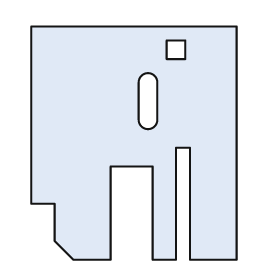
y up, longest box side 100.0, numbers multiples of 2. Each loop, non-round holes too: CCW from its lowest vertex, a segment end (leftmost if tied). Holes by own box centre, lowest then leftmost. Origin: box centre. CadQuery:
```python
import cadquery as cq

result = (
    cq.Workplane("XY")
    .moveTo(-26.0, -50.0)
    .lineTo(-10.0, -50.0)
    .lineTo(-10.0, -10.0)
    .lineTo(8.0, -10.0)
    .lineTo(8.0, -50.0)
    .lineTo(18.0, -50.0)
    .lineTo(18.0, -2.0)
    .lineTo(24.0, -2.0)
    .lineTo(24.0, -50.0)
    .lineTo(44.0, -50.0)
    .lineTo(44.0, 50.0)
    .lineTo(-44.0, 50.0)
    .lineTo(-44.0, -26.0)
    .lineTo(-34.0, -26.0)
    .lineTo(-34.0, -42.0)
    .close()
    .moveTo(2.0, 10.0)
    .threePointArc((6.0, 6.0), (10.0, 10.0))
    .lineTo(10.0, 26.0)
    .threePointArc((6.0, 30.0), (2.0, 26.0))
    .close()
    .moveTo(14.0, 36.0)
    .lineTo(22.0, 36.0)
    .lineTo(22.0, 44.0)
    .lineTo(14.0, 44.0)
    .close()
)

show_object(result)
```